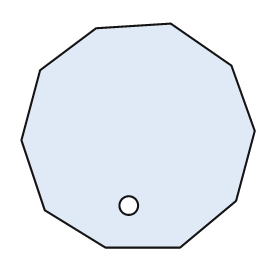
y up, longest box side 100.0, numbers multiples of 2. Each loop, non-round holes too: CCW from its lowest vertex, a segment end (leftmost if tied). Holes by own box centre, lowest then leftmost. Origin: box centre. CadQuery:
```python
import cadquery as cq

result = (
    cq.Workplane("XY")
    .moveTo(-14.0, -48.0)
    .lineTo(18.0, -48.0)
    .lineTo(42.0, -28.0)
    .lineTo(50.0, 2.0)
    .lineTo(40.0, 30.0)
    .lineTo(14.0, 48.0)
    .lineTo(-18.0, 46.0)
    .lineTo(-42.0, 28.0)
    .lineTo(-50.0, -2.0)
    .lineTo(-40.0, -32.0)
    .close()
    .moveTo(-4.0, -30.0)
    .circle(4.0)
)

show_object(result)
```